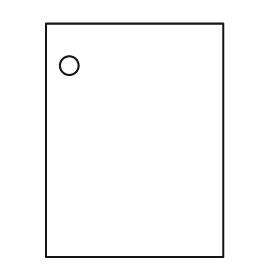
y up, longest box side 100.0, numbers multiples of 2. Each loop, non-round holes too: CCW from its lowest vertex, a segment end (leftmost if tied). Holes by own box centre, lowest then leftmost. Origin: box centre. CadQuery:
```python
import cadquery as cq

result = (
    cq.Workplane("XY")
    .moveTo(-38.0, -50.0)
    .lineTo(38.0, -50.0)
    .lineTo(38.0, 50.0)
    .lineTo(-38.0, 50.0)
    .close()
    .moveTo(-28.0, 32.0)
    .circle(4.0)
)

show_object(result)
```